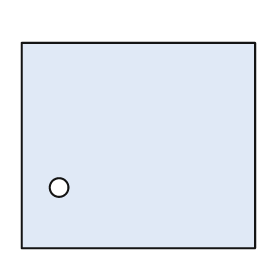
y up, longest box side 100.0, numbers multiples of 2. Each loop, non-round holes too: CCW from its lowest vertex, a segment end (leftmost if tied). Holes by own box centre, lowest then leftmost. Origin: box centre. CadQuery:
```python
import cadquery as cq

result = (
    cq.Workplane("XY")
    .moveTo(-50.0, -44.0)
    .lineTo(50.0, -44.0)
    .lineTo(50.0, 44.0)
    .lineTo(-50.0, 44.0)
    .close()
    .moveTo(-34.0, -18.0)
    .circle(4.0)
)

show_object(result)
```